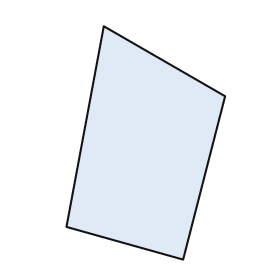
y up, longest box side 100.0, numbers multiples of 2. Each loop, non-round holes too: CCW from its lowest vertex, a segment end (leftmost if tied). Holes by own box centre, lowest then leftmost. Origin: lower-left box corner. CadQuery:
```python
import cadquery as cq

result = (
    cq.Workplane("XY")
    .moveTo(50.0, 0.0)
    .lineTo(68.0, 70.0)
    .lineTo(16.0, 100.0)
    .lineTo(0.0, 14.0)
    .close()
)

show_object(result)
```